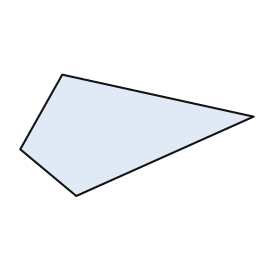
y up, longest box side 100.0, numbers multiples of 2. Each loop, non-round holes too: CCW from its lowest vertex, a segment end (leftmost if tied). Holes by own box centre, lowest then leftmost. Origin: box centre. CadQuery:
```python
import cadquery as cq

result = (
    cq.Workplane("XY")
    .moveTo(-26.0, -26.0)
    .lineTo(50.0, 8.0)
    .lineTo(-32.0, 26.0)
    .lineTo(-50.0, -6.0)
    .close()
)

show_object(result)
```